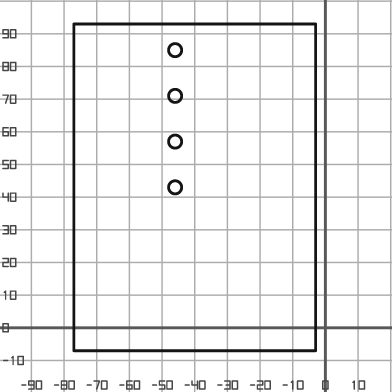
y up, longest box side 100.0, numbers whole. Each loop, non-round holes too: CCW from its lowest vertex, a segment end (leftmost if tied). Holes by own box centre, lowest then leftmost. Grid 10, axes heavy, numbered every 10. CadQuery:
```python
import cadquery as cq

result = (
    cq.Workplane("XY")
    .moveTo(-77.0, -7.0)
    .lineTo(-3.0, -7.0)
    .lineTo(-3.0, 93.0)
    .lineTo(-77.0, 93.0)
    .close()
    .moveTo(-46.0, 43.0)
    .circle(2.0)
    .moveTo(-46.0, 57.0)
    .circle(2.0)
    .moveTo(-46.0, 71.0)
    .circle(2.0)
    .moveTo(-46.0, 85.0)
    .circle(2.0)
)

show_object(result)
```